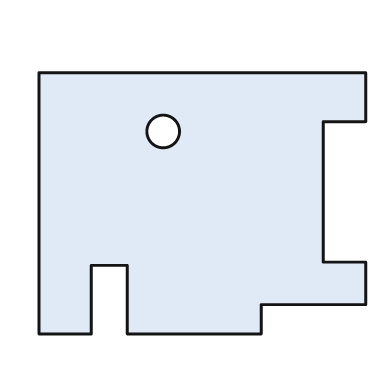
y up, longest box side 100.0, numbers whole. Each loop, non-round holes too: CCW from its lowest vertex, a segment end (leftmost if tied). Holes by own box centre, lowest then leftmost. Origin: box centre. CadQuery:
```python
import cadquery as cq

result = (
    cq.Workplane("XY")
    .moveTo(-50.0, -40.0)
    .lineTo(-34.0, -40.0)
    .lineTo(-34.0, -19.0)
    .lineTo(-23.0, -19.0)
    .lineTo(-23.0, -40.0)
    .lineTo(18.0, -40.0)
    .lineTo(18.0, -31.0)
    .lineTo(50.0, -31.0)
    .lineTo(50.0, -18.0)
    .lineTo(37.0, -18.0)
    .lineTo(37.0, 25.0)
    .lineTo(50.0, 25.0)
    .lineTo(50.0, 40.0)
    .lineTo(-50.0, 40.0)
    .close()
    .moveTo(-12.0, 22.0)
    .circle(5.0)
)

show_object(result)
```